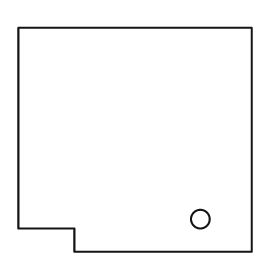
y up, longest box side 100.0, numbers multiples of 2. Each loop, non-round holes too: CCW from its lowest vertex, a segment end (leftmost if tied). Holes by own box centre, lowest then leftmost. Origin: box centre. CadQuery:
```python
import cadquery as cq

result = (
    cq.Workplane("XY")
    .moveTo(-26.0, -48.0)
    .lineTo(50.0, -48.0)
    .lineTo(50.0, 48.0)
    .lineTo(-50.0, 48.0)
    .lineTo(-50.0, -38.0)
    .lineTo(-26.0, -38.0)
    .close()
    .moveTo(28.0, -34.0)
    .circle(4.0)
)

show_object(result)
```